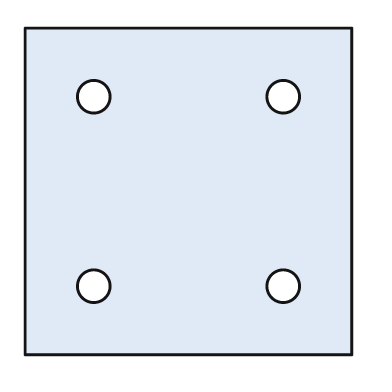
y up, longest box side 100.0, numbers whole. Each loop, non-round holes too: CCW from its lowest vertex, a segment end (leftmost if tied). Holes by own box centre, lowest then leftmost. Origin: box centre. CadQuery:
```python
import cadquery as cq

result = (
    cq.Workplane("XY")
    .moveTo(-50.0, -50.0)
    .lineTo(50.0, -50.0)
    .lineTo(50.0, 50.0)
    .lineTo(-50.0, 50.0)
    .close()
    .moveTo(-29.0, -29.0)
    .circle(5.0)
    .moveTo(29.0, -29.0)
    .circle(5.0)
    .moveTo(-29.0, 29.0)
    .circle(5.0)
    .moveTo(29.0, 29.0)
    .circle(5.0)
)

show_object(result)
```